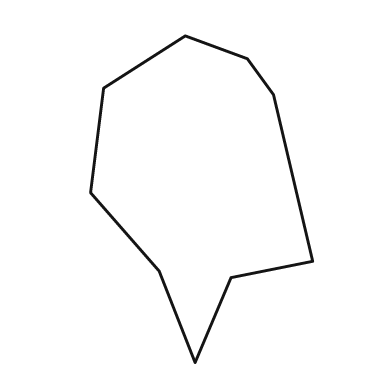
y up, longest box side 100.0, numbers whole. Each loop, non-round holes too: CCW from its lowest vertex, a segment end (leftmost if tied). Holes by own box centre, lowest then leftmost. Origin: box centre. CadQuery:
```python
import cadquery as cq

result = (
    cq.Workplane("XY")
    .moveTo(-2.0, -50.0)
    .lineTo(9.0, -24.0)
    .lineTo(34.0, -19.0)
    .lineTo(22.0, 32.0)
    .lineTo(14.0, 43.0)
    .lineTo(-5.0, 50.0)
    .lineTo(-30.0, 34.0)
    .lineTo(-34.0, 2.0)
    .lineTo(-13.0, -22.0)
    .close()
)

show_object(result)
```